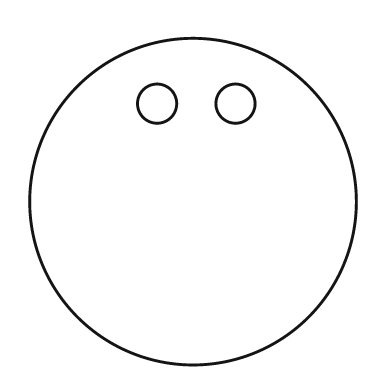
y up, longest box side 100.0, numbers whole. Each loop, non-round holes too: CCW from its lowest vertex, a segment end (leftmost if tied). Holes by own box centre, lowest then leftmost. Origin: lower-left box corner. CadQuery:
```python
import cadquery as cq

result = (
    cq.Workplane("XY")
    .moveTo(50.0, 50.0)
    .circle(50.0)
    .moveTo(39.0, 80.0)
    .circle(6.0)
    .moveTo(63.0, 80.0)
    .circle(6.0)
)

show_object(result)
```